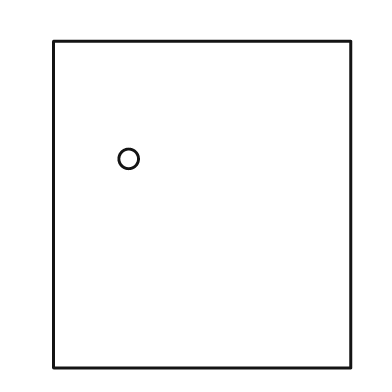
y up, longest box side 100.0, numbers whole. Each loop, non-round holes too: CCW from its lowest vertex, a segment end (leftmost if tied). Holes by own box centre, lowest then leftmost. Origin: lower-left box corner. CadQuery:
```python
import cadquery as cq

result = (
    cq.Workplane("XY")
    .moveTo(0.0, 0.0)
    .lineTo(91.0, 0.0)
    .lineTo(91.0, 100.0)
    .lineTo(0.0, 100.0)
    .close()
    .moveTo(23.0, 64.0)
    .circle(3.0)
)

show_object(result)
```